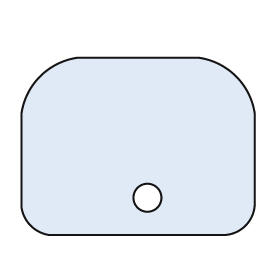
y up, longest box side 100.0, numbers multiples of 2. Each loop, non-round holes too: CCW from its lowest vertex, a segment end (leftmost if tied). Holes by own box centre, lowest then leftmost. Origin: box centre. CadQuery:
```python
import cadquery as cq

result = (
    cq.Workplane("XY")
    .moveTo(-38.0, -38.0)
    .lineTo(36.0, -38.0)
    .threePointArc((46.0, -34.0), (50.0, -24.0))
    .lineTo(50.0, 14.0)
    .threePointArc((42.0, 30.0), (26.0, 38.0))
    .lineTo(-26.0, 38.0)
    .threePointArc((-42.0, 30.0), (-50.0, 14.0))
    .lineTo(-50.0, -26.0)
    .threePointArc((-46.0, -34.0), (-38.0, -38.0))
    .close()
    .moveTo(4.0, -22.0)
    .circle(6.0)
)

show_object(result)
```